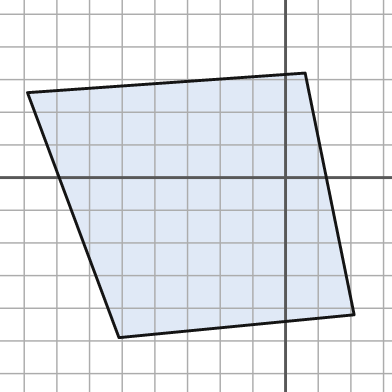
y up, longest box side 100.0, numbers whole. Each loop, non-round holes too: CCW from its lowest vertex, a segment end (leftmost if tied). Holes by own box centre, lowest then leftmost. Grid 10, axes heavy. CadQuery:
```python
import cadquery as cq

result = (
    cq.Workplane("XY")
    .moveTo(-51.0, -49.0)
    .lineTo(21.0, -42.0)
    .lineTo(6.0, 32.0)
    .lineTo(-79.0, 26.0)
    .close()
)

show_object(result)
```